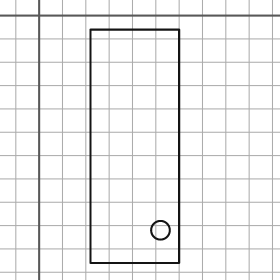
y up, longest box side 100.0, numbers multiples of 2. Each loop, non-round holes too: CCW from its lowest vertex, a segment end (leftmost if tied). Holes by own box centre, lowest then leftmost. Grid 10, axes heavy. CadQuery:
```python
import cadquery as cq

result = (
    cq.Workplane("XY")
    .moveTo(22.0, -106.0)
    .lineTo(60.0, -106.0)
    .lineTo(60.0, -6.0)
    .lineTo(22.0, -6.0)
    .close()
    .moveTo(52.0, -92.0)
    .circle(4.0)
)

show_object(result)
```